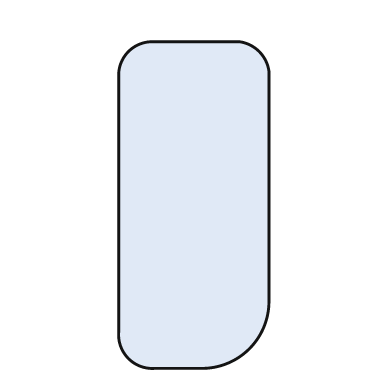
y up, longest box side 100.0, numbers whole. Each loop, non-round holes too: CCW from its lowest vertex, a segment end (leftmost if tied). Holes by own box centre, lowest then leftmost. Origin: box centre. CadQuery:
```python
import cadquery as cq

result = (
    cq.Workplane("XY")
    .moveTo(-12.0, -50.0)
    .lineTo(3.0, -50.0)
    .threePointArc((17.0, -44.0), (23.0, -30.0))
    .lineTo(23.0, 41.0)
    .threePointArc((20.0, 47.0), (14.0, 50.0))
    .lineTo(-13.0, 50.0)
    .threePointArc((-20.0, 47.0), (-23.0, 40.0))
    .lineTo(-23.0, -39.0)
    .threePointArc((-20.0, -47.0), (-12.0, -50.0))
    .close()
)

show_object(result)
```